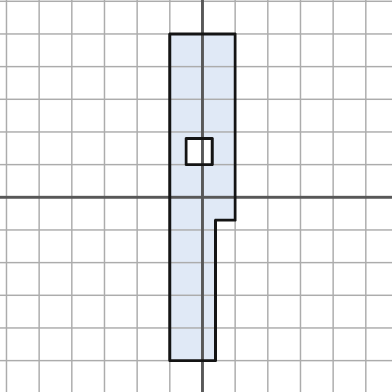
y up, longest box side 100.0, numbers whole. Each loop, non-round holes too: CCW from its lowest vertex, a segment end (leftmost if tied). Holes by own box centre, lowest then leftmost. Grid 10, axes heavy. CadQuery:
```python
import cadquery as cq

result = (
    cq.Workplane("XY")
    .moveTo(-10.0, -50.0)
    .lineTo(4.0, -50.0)
    .lineTo(4.0, -7.0)
    .lineTo(10.0, -7.0)
    .lineTo(10.0, 50.0)
    .lineTo(-10.0, 50.0)
    .close()
    .moveTo(-5.0, 10.0)
    .lineTo(3.0, 10.0)
    .lineTo(3.0, 18.0)
    .lineTo(-5.0, 18.0)
    .close()
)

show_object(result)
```